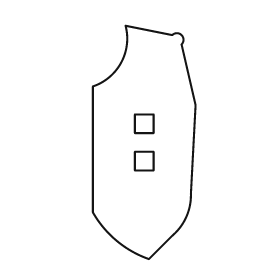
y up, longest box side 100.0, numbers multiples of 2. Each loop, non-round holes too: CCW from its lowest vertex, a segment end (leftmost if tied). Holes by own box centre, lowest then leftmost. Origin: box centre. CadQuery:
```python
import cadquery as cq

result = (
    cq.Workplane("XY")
    .moveTo(2.0, -50.0)
    .lineTo(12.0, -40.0)
    .threePointArc((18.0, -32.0), (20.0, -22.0))
    .lineTo(22.0, 16.0)
    .lineTo(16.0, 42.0)
    .threePointArc((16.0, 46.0), (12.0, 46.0))
    .lineTo(-8.0, 50.0)
    .threePointArc((-10.0, 34.0), (-22.0, 24.0))
    .lineTo(-22.0, -30.0)
    .threePointArc((-12.0, -42.0), (2.0, -50.0))
    .close()
    .moveTo(-4.0, -12.0)
    .lineTo(4.0, -12.0)
    .lineTo(4.0, -4.0)
    .lineTo(-4.0, -4.0)
    .close()
    .moveTo(-4.0, 4.0)
    .lineTo(4.0, 4.0)
    .lineTo(4.0, 12.0)
    .lineTo(-4.0, 12.0)
    .close()
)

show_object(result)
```